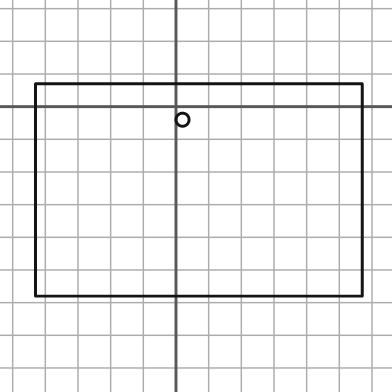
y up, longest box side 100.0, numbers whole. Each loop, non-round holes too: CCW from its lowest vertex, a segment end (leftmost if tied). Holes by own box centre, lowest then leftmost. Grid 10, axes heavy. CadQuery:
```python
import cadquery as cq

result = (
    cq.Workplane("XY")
    .moveTo(-43.0, -58.0)
    .lineTo(57.0, -58.0)
    .lineTo(57.0, 7.0)
    .lineTo(-43.0, 7.0)
    .close()
    .moveTo(2.0, -4.0)
    .circle(2.0)
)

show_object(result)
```